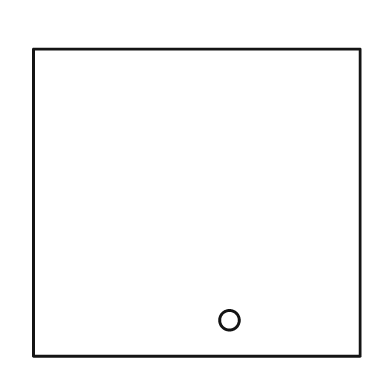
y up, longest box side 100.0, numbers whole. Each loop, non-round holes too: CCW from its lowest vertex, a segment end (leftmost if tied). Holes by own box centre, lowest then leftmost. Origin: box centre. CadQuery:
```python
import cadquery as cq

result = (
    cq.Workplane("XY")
    .moveTo(-50.0, -47.0)
    .lineTo(50.0, -47.0)
    .lineTo(50.0, 47.0)
    .lineTo(-50.0, 47.0)
    .close()
    .moveTo(10.0, -36.0)
    .circle(3.0)
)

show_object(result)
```